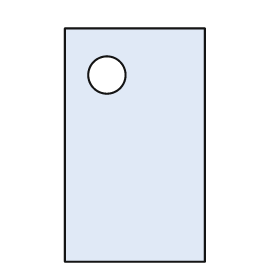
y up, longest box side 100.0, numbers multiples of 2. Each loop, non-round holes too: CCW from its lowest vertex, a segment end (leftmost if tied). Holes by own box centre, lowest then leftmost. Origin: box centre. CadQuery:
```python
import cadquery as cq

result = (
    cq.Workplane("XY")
    .moveTo(-30.0, -50.0)
    .lineTo(30.0, -50.0)
    .lineTo(30.0, 50.0)
    .lineTo(-30.0, 50.0)
    .close()
    .moveTo(-12.0, 30.0)
    .circle(8.0)
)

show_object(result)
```